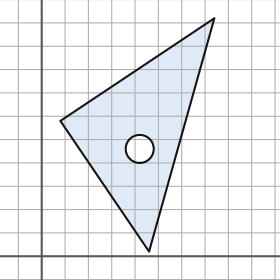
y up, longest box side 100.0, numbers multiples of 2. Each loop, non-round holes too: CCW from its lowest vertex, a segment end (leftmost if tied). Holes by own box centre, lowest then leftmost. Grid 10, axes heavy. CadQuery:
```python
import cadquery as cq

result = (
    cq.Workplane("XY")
    .moveTo(46.0, 2.0)
    .lineTo(74.0, 102.0)
    .lineTo(8.0, 58.0)
    .close()
    .moveTo(42.0, 46.0)
    .circle(6.0)
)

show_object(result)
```